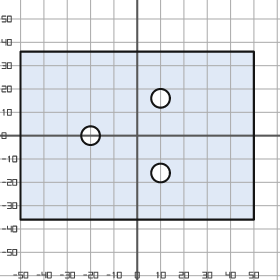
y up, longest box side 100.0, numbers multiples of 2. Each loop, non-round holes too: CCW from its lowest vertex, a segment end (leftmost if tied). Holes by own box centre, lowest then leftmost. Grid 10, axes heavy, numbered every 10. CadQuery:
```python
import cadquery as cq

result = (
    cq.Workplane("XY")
    .moveTo(-50.0, -36.0)
    .lineTo(50.0, -36.0)
    .lineTo(50.0, 36.0)
    .lineTo(-50.0, 36.0)
    .close()
    .moveTo(10.0, -16.0)
    .circle(4.0)
    .moveTo(-20.0, 0.0)
    .circle(4.0)
    .moveTo(10.0, 16.0)
    .circle(4.0)
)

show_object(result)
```